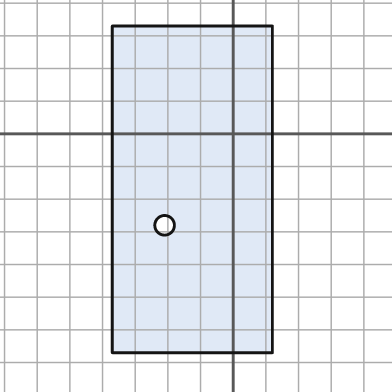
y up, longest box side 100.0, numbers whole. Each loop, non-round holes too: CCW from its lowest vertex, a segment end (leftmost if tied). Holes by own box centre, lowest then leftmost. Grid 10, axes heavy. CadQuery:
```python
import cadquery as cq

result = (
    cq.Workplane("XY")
    .moveTo(-37.0, -67.0)
    .lineTo(12.0, -67.0)
    .lineTo(12.0, 33.0)
    .lineTo(-37.0, 33.0)
    .close()
    .moveTo(-21.0, -28.0)
    .circle(3.0)
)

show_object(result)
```